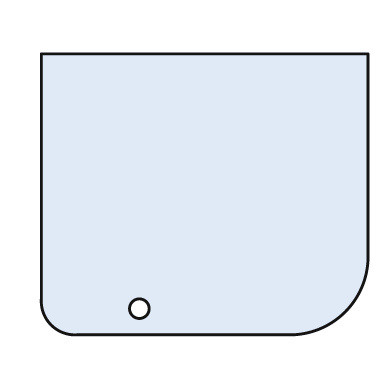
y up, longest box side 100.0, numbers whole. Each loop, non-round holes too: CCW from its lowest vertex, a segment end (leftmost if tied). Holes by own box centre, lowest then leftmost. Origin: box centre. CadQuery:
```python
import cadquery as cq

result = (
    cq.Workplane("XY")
    .moveTo(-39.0, -43.0)
    .lineTo(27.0, -43.0)
    .threePointArc((43.0, -36.0), (50.0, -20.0))
    .lineTo(50.0, 43.0)
    .lineTo(-50.0, 43.0)
    .lineTo(-50.0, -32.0)
    .threePointArc((-47.0, -40.0), (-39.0, -43.0))
    .close()
    .moveTo(-20.0, -35.0)
    .circle(3.0)
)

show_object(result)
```